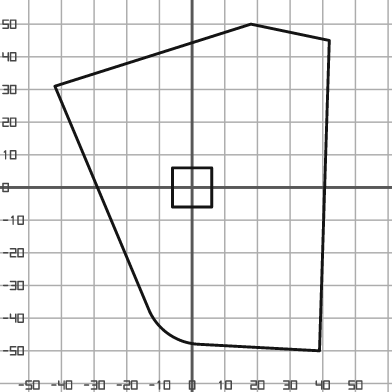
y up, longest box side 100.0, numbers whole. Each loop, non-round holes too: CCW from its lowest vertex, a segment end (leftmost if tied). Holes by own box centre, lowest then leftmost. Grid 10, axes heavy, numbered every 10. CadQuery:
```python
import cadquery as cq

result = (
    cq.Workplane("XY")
    .moveTo(39.0, -50.0)
    .lineTo(42.0, 45.0)
    .lineTo(18.0, 50.0)
    .lineTo(-42.0, 31.0)
    .lineTo(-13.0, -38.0)
    .threePointArc((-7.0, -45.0), (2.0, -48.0))
    .close()
    .moveTo(-6.0, -6.0)
    .lineTo(6.0, -6.0)
    .lineTo(6.0, 6.0)
    .lineTo(-6.0, 6.0)
    .close()
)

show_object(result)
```